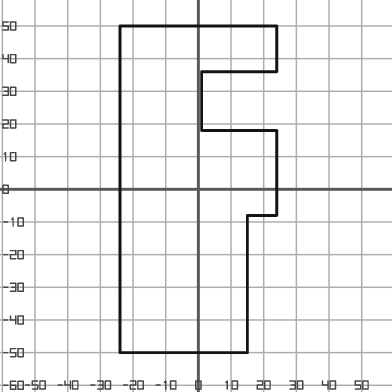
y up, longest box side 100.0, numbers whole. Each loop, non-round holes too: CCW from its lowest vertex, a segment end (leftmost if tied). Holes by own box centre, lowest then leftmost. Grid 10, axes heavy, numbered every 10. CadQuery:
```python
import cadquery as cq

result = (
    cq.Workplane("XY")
    .moveTo(-24.0, -50.0)
    .lineTo(15.0, -50.0)
    .lineTo(15.0, -8.0)
    .lineTo(24.0, -8.0)
    .lineTo(24.0, 18.0)
    .lineTo(1.0, 18.0)
    .lineTo(1.0, 36.0)
    .lineTo(24.0, 36.0)
    .lineTo(24.0, 50.0)
    .lineTo(-24.0, 50.0)
    .close()
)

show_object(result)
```